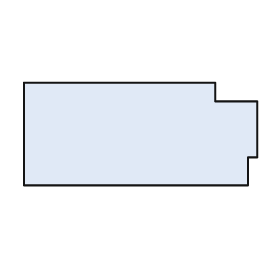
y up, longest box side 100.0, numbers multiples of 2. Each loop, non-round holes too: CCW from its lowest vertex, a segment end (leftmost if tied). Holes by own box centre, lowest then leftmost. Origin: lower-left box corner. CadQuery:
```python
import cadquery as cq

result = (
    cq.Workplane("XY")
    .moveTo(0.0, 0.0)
    .lineTo(96.0, 0.0)
    .lineTo(96.0, 12.0)
    .lineTo(100.0, 12.0)
    .lineTo(100.0, 36.0)
    .lineTo(82.0, 36.0)
    .lineTo(82.0, 44.0)
    .lineTo(0.0, 44.0)
    .close()
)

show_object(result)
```